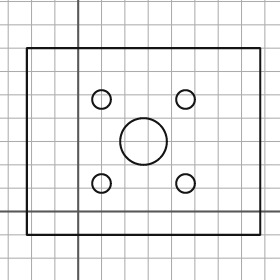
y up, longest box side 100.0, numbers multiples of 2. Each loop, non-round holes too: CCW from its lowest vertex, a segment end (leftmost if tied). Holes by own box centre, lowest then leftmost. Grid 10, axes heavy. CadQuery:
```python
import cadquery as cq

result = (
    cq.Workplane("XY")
    .moveTo(-22.0, -10.0)
    .lineTo(78.0, -10.0)
    .lineTo(78.0, 70.0)
    .lineTo(-22.0, 70.0)
    .close()
    .moveTo(10.0, 12.0)
    .circle(4.0)
    .moveTo(46.0, 12.0)
    .circle(4.0)
    .moveTo(28.0, 30.0)
    .circle(10.0)
    .moveTo(10.0, 48.0)
    .circle(4.0)
    .moveTo(46.0, 48.0)
    .circle(4.0)
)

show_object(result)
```